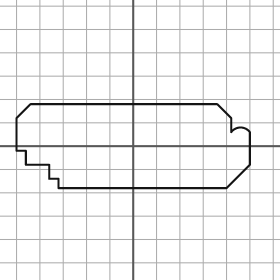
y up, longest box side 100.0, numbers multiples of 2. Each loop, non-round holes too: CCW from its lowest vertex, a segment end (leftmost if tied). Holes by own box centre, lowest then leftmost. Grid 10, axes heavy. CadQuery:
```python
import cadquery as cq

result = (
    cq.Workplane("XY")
    .moveTo(-32.0, -18.0)
    .lineTo(40.0, -18.0)
    .lineTo(50.0, -8.0)
    .lineTo(50.0, 6.0)
    .threePointArc((46.0, 8.0), (42.0, 6.0))
    .lineTo(42.0, 12.0)
    .lineTo(36.0, 18.0)
    .lineTo(-44.0, 18.0)
    .lineTo(-50.0, 12.0)
    .lineTo(-50.0, -2.0)
    .lineTo(-46.0, -2.0)
    .lineTo(-46.0, -8.0)
    .lineTo(-36.0, -8.0)
    .lineTo(-36.0, -14.0)
    .lineTo(-32.0, -14.0)
    .close()
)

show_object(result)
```